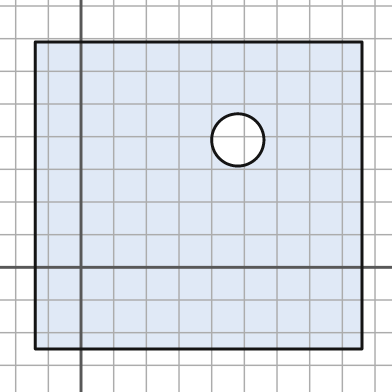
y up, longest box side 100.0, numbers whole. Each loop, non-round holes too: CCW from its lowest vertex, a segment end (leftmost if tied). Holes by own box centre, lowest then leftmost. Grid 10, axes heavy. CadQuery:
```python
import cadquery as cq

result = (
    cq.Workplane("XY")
    .moveTo(-14.0, -25.0)
    .lineTo(86.0, -25.0)
    .lineTo(86.0, 69.0)
    .lineTo(-14.0, 69.0)
    .close()
    .moveTo(48.0, 39.0)
    .circle(8.0)
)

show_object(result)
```